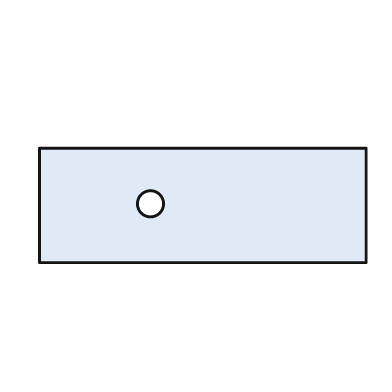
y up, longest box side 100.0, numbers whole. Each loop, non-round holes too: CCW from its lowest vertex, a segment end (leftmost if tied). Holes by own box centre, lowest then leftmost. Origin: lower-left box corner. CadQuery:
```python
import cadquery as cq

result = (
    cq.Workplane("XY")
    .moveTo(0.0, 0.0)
    .lineTo(100.0, 0.0)
    .lineTo(100.0, 35.0)
    .lineTo(0.0, 35.0)
    .close()
    .moveTo(34.0, 18.0)
    .circle(4.0)
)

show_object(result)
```